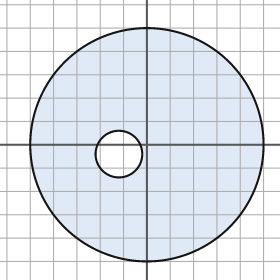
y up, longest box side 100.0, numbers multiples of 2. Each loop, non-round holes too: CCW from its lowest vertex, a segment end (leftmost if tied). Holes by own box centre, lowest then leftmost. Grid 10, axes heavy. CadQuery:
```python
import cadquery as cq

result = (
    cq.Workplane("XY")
    .moveTo(0.0, 0.0)
    .circle(50.0)
    .moveTo(-12.0, -4.0)
    .circle(10.0)
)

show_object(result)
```